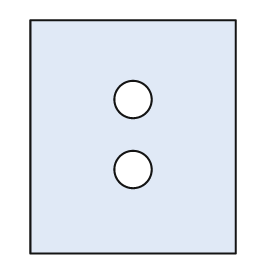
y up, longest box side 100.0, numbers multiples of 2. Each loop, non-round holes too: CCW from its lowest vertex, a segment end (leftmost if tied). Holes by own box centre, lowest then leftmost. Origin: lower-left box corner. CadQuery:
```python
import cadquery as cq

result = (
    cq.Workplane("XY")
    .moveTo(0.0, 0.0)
    .lineTo(88.0, 0.0)
    .lineTo(88.0, 100.0)
    .lineTo(0.0, 100.0)
    .close()
    .moveTo(44.0, 36.0)
    .circle(8.0)
    .moveTo(44.0, 66.0)
    .circle(8.0)
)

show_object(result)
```